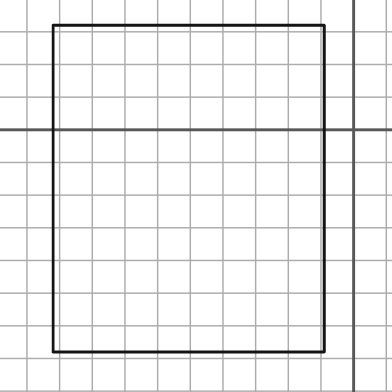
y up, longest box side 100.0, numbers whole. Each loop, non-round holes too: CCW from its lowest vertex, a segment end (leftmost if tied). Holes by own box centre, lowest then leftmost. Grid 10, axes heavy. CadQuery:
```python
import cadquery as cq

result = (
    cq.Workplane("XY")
    .moveTo(-92.0, -68.0)
    .lineTo(-9.0, -68.0)
    .lineTo(-9.0, 32.0)
    .lineTo(-92.0, 32.0)
    .close()
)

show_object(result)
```